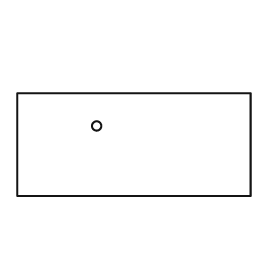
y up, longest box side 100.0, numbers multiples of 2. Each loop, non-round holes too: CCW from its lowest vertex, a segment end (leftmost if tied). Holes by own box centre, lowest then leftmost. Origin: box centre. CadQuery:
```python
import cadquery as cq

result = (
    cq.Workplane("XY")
    .moveTo(-50.0, -22.0)
    .lineTo(50.0, -22.0)
    .lineTo(50.0, 22.0)
    .lineTo(-50.0, 22.0)
    .close()
    .moveTo(-16.0, 8.0)
    .circle(2.0)
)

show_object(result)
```